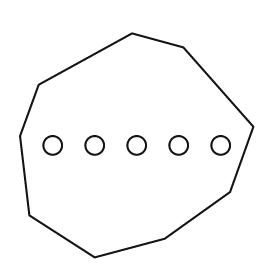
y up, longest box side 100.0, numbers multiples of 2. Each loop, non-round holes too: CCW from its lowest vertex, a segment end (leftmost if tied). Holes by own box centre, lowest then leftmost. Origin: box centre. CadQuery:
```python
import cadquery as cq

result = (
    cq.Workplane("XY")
    .moveTo(-18.0, -48.0)
    .lineTo(12.0, -40.0)
    .lineTo(40.0, -20.0)
    .lineTo(50.0, 8.0)
    .lineTo(20.0, 42.0)
    .lineTo(-2.0, 48.0)
    .lineTo(-42.0, 26.0)
    .lineTo(-50.0, 4.0)
    .lineTo(-46.0, -30.0)
    .close()
    .moveTo(-36.0, 0.0)
    .circle(4.0)
    .moveTo(-18.0, 0.0)
    .circle(4.0)
    .moveTo(0.0, 0.0)
    .circle(4.0)
    .moveTo(18.0, 0.0)
    .circle(4.0)
    .moveTo(36.0, 0.0)
    .circle(4.0)
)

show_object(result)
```